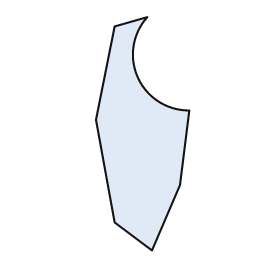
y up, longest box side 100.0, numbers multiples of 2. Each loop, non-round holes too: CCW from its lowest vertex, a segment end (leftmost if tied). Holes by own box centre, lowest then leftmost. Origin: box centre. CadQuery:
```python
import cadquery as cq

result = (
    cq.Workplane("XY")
    .moveTo(4.0, -50.0)
    .lineTo(16.0, -22.0)
    .lineTo(20.0, 10.0)
    .threePointArc((-2.0, 24.0), (2.0, 50.0))
    .lineTo(-12.0, 46.0)
    .lineTo(-20.0, 6.0)
    .lineTo(-12.0, -38.0)
    .close()
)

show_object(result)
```